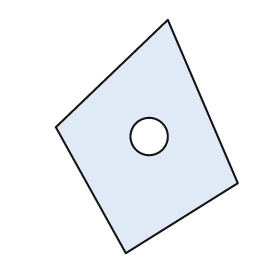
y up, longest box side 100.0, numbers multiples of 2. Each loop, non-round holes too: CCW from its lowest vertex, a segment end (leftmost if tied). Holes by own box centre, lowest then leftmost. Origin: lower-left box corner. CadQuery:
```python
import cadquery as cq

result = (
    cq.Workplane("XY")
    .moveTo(30.0, 0.0)
    .lineTo(78.0, 30.0)
    .lineTo(48.0, 100.0)
    .lineTo(0.0, 54.0)
    .close()
    .moveTo(40.0, 50.0)
    .circle(8.0)
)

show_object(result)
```